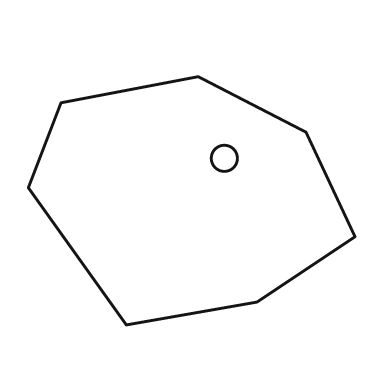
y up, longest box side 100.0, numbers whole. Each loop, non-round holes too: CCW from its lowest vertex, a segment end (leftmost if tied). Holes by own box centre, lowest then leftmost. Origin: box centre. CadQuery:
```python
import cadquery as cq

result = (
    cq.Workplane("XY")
    .moveTo(-20.0, -38.0)
    .lineTo(20.0, -31.0)
    .lineTo(50.0, -11.0)
    .lineTo(35.0, 21.0)
    .lineTo(2.0, 38.0)
    .lineTo(-40.0, 30.0)
    .lineTo(-50.0, 4.0)
    .close()
    .moveTo(10.0, 13.0)
    .circle(4.0)
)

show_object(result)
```